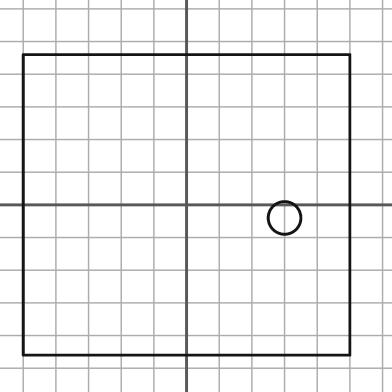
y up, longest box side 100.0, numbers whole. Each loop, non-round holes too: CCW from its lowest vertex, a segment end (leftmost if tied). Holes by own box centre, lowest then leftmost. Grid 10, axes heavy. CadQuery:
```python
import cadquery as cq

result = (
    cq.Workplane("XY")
    .moveTo(-50.0, -46.0)
    .lineTo(50.0, -46.0)
    .lineTo(50.0, 46.0)
    .lineTo(-50.0, 46.0)
    .close()
    .moveTo(30.0, -4.0)
    .circle(5.0)
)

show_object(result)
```